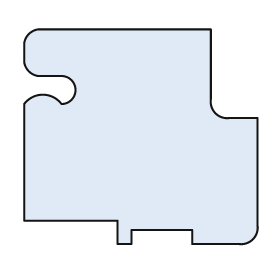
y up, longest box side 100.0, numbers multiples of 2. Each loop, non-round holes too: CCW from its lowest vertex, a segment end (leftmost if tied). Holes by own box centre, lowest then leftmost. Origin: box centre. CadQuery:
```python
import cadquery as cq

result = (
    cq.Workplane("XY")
    .moveTo(-10.0, -46.0)
    .lineTo(-4.0, -46.0)
    .lineTo(-4.0, -40.0)
    .lineTo(22.0, -40.0)
    .lineTo(22.0, -46.0)
    .lineTo(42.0, -46.0)
    .threePointArc((48.0, -44.0), (50.0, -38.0))
    .lineTo(50.0, 8.0)
    .lineTo(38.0, 8.0)
    .threePointArc((32.0, 10.0), (30.0, 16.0))
    .lineTo(30.0, 46.0)
    .lineTo(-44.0, 46.0)
    .threePointArc((-48.0, 44.0), (-50.0, 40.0))
    .lineTo(-50.0, 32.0)
    .threePointArc((-48.0, 28.0), (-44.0, 26.0))
    .lineTo(-34.0, 26.0)
    .threePointArc((-28.0, 20.0), (-34.0, 14.0))
    .threePointArc((-42.0, 18.0), (-50.0, 14.0))
    .lineTo(-50.0, -36.0)
    .lineTo(-10.0, -36.0)
    .close()
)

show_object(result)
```